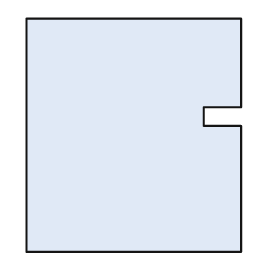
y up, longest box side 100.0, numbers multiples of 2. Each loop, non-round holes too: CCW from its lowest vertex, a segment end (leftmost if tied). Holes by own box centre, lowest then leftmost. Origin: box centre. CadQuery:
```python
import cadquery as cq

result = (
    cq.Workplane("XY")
    .moveTo(-46.0, -50.0)
    .lineTo(46.0, -50.0)
    .lineTo(46.0, 4.0)
    .lineTo(30.0, 4.0)
    .lineTo(30.0, 12.0)
    .lineTo(46.0, 12.0)
    .lineTo(46.0, 50.0)
    .lineTo(-46.0, 50.0)
    .close()
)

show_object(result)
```